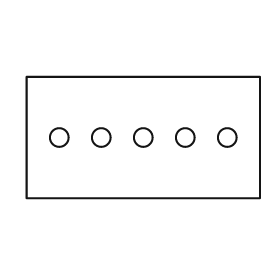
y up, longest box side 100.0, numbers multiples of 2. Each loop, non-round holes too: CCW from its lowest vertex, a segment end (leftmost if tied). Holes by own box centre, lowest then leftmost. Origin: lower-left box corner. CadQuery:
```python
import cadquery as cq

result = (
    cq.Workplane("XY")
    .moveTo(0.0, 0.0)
    .lineTo(100.0, 0.0)
    .lineTo(100.0, 52.0)
    .lineTo(0.0, 52.0)
    .close()
    .moveTo(14.0, 26.0)
    .circle(4.0)
    .moveTo(32.0, 26.0)
    .circle(4.0)
    .moveTo(50.0, 26.0)
    .circle(4.0)
    .moveTo(68.0, 26.0)
    .circle(4.0)
    .moveTo(86.0, 26.0)
    .circle(4.0)
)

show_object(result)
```